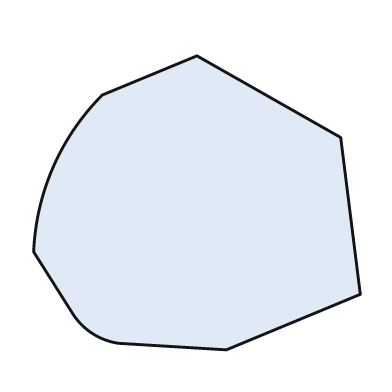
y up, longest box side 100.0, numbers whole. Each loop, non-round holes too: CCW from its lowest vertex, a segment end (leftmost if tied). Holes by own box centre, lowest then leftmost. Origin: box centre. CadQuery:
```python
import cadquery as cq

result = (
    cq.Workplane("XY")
    .moveTo(9.0, -45.0)
    .lineTo(50.0, -28.0)
    .lineTo(44.0, 20.0)
    .lineTo(0.0, 45.0)
    .lineTo(-29.0, 33.0)
    .threePointArc((-44.0, 11.0), (-50.0, -15.0))
    .lineTo(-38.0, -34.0)
    .threePointArc((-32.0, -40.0), (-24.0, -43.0))
    .close()
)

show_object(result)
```